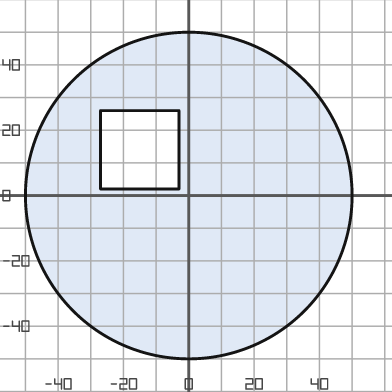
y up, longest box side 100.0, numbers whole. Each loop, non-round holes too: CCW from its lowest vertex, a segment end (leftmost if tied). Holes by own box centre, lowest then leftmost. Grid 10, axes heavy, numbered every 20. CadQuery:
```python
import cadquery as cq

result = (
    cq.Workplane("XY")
    .moveTo(0.0, 0.0)
    .circle(50.0)
    .moveTo(-27.0, 2.0)
    .lineTo(-3.0, 2.0)
    .lineTo(-3.0, 26.0)
    .lineTo(-27.0, 26.0)
    .close()
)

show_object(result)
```